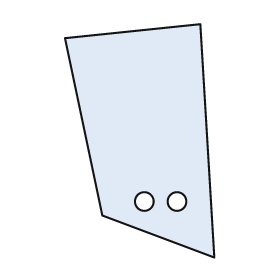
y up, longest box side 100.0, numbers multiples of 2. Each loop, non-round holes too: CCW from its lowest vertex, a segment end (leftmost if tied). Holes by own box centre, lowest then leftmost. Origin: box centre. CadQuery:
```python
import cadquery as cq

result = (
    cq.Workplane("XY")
    .moveTo(32.0, -50.0)
    .lineTo(26.0, 50.0)
    .lineTo(-32.0, 44.0)
    .lineTo(-16.0, -32.0)
    .close()
    .moveTo(2.0, -26.0)
    .circle(4.0)
    .moveTo(16.0, -26.0)
    .circle(4.0)
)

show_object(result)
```